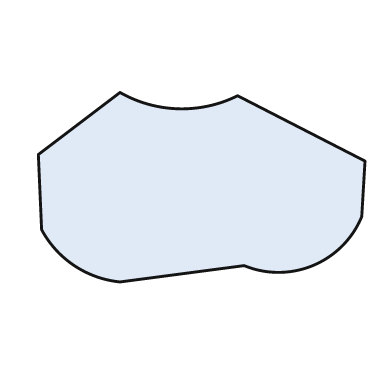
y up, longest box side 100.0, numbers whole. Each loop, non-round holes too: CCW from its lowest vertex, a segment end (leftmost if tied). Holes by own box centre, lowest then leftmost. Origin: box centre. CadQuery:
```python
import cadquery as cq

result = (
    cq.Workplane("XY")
    .moveTo(-25.0, -29.0)
    .lineTo(13.0, -24.0)
    .threePointArc((34.0, -24.0), (49.0, -9.0))
    .lineTo(50.0, 8.0)
    .lineTo(11.0, 28.0)
    .threePointArc((-7.0, 24.0), (-25.0, 29.0))
    .lineTo(-50.0, 10.0)
    .lineTo(-49.0, -13.0)
    .threePointArc((-39.0, -24.0), (-25.0, -29.0))
    .close()
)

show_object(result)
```